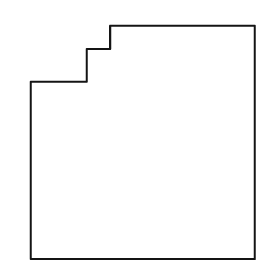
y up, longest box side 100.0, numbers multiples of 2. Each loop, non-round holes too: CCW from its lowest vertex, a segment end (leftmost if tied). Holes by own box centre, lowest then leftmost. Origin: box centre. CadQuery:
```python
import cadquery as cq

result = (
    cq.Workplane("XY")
    .moveTo(-48.0, -50.0)
    .lineTo(48.0, -50.0)
    .lineTo(48.0, 50.0)
    .lineTo(-14.0, 50.0)
    .lineTo(-14.0, 40.0)
    .lineTo(-24.0, 40.0)
    .lineTo(-24.0, 26.0)
    .lineTo(-48.0, 26.0)
    .close()
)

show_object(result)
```